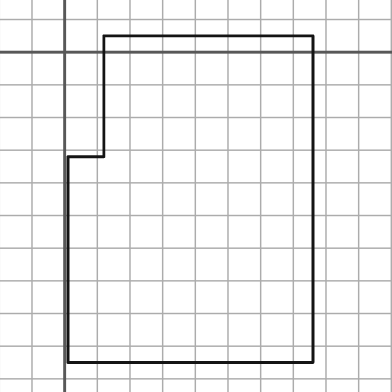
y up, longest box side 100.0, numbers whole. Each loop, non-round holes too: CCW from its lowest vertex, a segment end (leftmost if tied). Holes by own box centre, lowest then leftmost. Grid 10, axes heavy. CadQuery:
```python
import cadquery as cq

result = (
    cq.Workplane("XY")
    .moveTo(1.0, -95.0)
    .lineTo(76.0, -95.0)
    .lineTo(76.0, 5.0)
    .lineTo(12.0, 5.0)
    .lineTo(12.0, -32.0)
    .lineTo(1.0, -32.0)
    .close()
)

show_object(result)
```